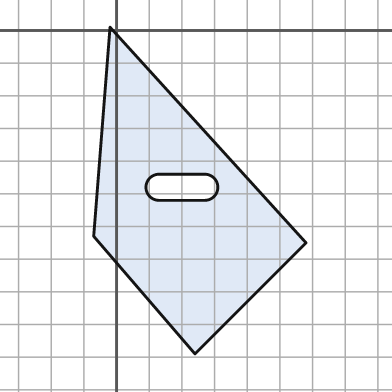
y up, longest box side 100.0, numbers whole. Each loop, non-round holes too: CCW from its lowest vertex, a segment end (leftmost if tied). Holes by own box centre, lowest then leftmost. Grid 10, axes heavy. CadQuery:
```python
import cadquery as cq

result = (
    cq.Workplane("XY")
    .moveTo(24.0, -99.0)
    .lineTo(58.0, -65.0)
    .lineTo(-2.0, 1.0)
    .lineTo(-7.0, -63.0)
    .close()
    .moveTo(13.0, -52.0)
    .lineTo(27.0, -52.0)
    .threePointArc((31.0, -48.0), (27.0, -44.0))
    .lineTo(13.0, -44.0)
    .threePointArc((9.0, -48.0), (13.0, -52.0))
    .close()
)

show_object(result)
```